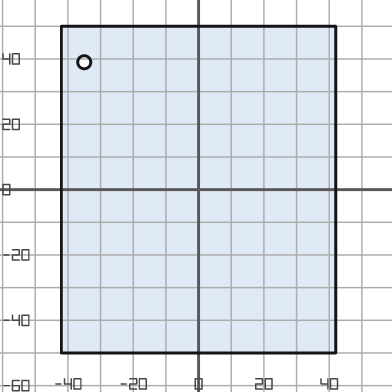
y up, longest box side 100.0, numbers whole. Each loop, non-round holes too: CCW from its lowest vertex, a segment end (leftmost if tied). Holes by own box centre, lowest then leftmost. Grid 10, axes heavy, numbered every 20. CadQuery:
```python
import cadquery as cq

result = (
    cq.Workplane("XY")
    .moveTo(-42.0, -50.0)
    .lineTo(42.0, -50.0)
    .lineTo(42.0, 50.0)
    .lineTo(-42.0, 50.0)
    .close()
    .moveTo(-35.0, 39.0)
    .circle(2.0)
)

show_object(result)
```